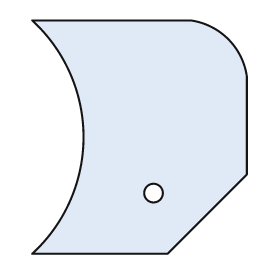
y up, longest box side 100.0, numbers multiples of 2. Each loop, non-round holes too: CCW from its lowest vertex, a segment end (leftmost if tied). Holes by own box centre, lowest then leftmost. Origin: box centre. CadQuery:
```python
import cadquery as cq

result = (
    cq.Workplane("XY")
    .moveTo(-46.0, -50.0)
    .lineTo(12.0, -50.0)
    .lineTo(46.0, -16.0)
    .lineTo(46.0, 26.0)
    .threePointArc((38.0, 42.0), (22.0, 50.0))
    .lineTo(-46.0, 50.0)
    .threePointArc((-24.0, 0.0), (-46.0, -50.0))
    .close()
    .moveTo(6.0, -24.0)
    .circle(4.0)
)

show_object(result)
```